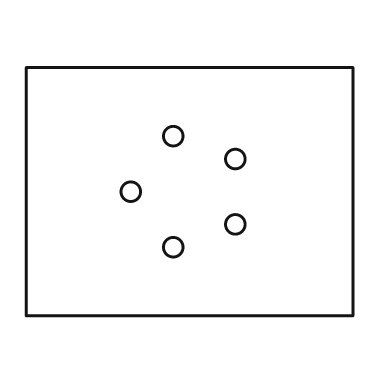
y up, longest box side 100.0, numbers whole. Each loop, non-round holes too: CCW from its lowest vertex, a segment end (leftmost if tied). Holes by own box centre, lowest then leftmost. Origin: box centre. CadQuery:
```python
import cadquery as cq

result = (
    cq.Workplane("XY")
    .moveTo(-50.0, -38.0)
    .lineTo(50.0, -38.0)
    .lineTo(50.0, 38.0)
    .lineTo(-50.0, 38.0)
    .close()
    .moveTo(-5.0, -17.0)
    .circle(3.0)
    .moveTo(14.0, -10.0)
    .circle(3.0)
    .moveTo(-18.0, 0.0)
    .circle(3.0)
    .moveTo(14.0, 10.0)
    .circle(3.0)
    .moveTo(-5.0, 17.0)
    .circle(3.0)
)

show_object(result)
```